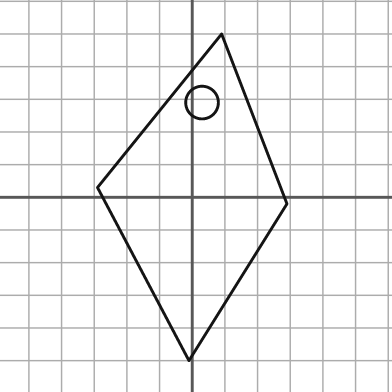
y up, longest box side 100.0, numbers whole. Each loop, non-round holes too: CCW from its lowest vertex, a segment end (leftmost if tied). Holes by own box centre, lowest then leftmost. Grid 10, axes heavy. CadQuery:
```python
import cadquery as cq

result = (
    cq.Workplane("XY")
    .moveTo(-1.0, -50.0)
    .lineTo(29.0, -2.0)
    .lineTo(9.0, 50.0)
    .lineTo(-29.0, 3.0)
    .close()
    .moveTo(3.0, 29.0)
    .circle(5.0)
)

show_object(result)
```